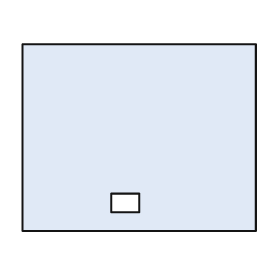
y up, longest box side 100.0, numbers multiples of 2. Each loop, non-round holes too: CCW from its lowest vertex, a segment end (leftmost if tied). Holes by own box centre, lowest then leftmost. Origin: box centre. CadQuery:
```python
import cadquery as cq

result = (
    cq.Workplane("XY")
    .moveTo(-50.0, -40.0)
    .lineTo(50.0, -40.0)
    .lineTo(50.0, 40.0)
    .lineTo(-50.0, 40.0)
    .close()
    .moveTo(-12.0, -32.0)
    .lineTo(0.0, -32.0)
    .lineTo(0.0, -24.0)
    .lineTo(-12.0, -24.0)
    .close()
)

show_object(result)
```